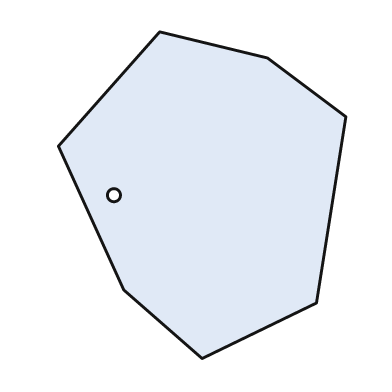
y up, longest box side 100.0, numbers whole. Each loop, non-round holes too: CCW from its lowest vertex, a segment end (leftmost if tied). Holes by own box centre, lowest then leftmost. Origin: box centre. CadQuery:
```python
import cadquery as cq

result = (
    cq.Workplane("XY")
    .moveTo(0.0, -50.0)
    .lineTo(35.0, -33.0)
    .lineTo(44.0, 24.0)
    .lineTo(20.0, 42.0)
    .lineTo(-13.0, 50.0)
    .lineTo(-44.0, 15.0)
    .lineTo(-24.0, -29.0)
    .close()
    .moveTo(-27.0, 0.0)
    .circle(2.0)
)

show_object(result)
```